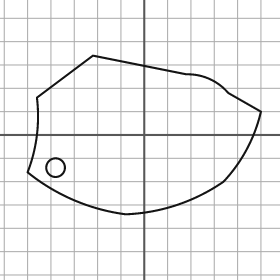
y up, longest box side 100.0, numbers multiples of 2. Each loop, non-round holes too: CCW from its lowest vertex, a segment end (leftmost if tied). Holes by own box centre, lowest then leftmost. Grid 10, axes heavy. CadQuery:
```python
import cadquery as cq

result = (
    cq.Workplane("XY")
    .moveTo(-8.0, -34.0)
    .threePointArc((14.0, -30.0), (34.0, -20.0))
    .threePointArc((44.0, -6.0), (50.0, 10.0))
    .lineTo(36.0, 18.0)
    .threePointArc((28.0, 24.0), (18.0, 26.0))
    .lineTo(-22.0, 34.0)
    .lineTo(-46.0, 16.0)
    .threePointArc((-46.0, 0.0), (-50.0, -16.0))
    .threePointArc((-30.0, -28.0), (-8.0, -34.0))
    .close()
    .moveTo(-38.0, -14.0)
    .circle(4.0)
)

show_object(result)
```